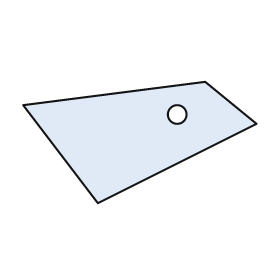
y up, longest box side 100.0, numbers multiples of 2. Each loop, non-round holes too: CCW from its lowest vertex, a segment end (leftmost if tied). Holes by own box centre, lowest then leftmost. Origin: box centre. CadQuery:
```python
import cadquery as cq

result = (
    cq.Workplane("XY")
    .moveTo(-18.0, -26.0)
    .lineTo(50.0, 8.0)
    .lineTo(28.0, 26.0)
    .lineTo(-50.0, 16.0)
    .close()
    .moveTo(16.0, 12.0)
    .circle(4.0)
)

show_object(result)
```